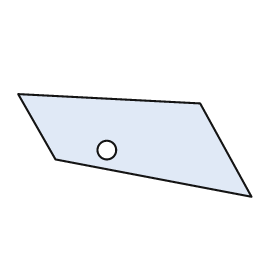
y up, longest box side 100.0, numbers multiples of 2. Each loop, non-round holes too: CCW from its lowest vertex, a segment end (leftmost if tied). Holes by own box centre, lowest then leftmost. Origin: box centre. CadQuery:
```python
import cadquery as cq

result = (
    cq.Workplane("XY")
    .moveTo(50.0, -22.0)
    .lineTo(28.0, 18.0)
    .lineTo(-50.0, 22.0)
    .lineTo(-34.0, -6.0)
    .close()
    .moveTo(-12.0, -2.0)
    .circle(4.0)
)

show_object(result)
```